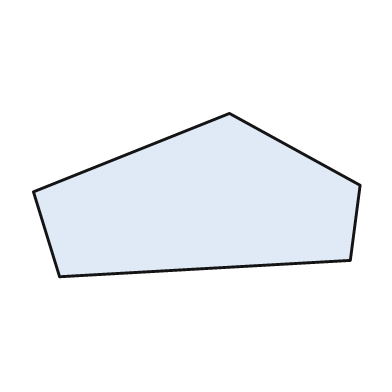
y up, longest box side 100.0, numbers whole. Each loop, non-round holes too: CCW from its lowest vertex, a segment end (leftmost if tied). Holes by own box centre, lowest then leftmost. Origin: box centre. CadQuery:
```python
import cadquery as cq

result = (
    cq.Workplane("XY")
    .moveTo(-42.0, -25.0)
    .lineTo(47.0, -20.0)
    .lineTo(50.0, 3.0)
    .lineTo(10.0, 25.0)
    .lineTo(-50.0, 1.0)
    .close()
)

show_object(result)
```